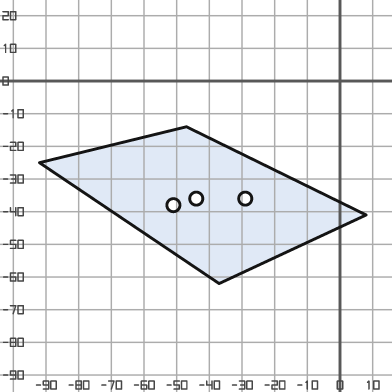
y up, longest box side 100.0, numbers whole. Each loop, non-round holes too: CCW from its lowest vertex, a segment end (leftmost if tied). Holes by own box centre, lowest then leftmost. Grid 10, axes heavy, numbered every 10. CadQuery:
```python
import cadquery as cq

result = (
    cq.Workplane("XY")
    .moveTo(-37.0, -62.0)
    .lineTo(8.0, -41.0)
    .lineTo(-47.0, -14.0)
    .lineTo(-92.0, -25.0)
    .close()
    .moveTo(-51.0, -38.0)
    .circle(2.0)
    .moveTo(-44.0, -36.0)
    .circle(2.0)
    .moveTo(-29.0, -36.0)
    .circle(2.0)
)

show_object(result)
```